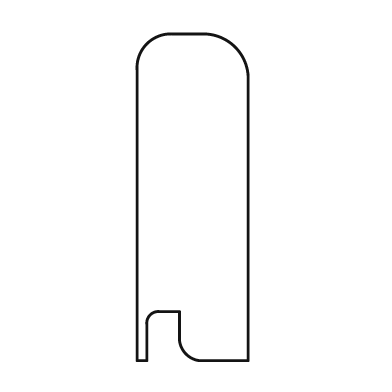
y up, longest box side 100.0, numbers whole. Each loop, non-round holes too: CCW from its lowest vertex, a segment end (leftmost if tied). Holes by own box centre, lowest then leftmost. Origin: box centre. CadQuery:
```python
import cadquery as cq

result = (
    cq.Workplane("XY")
    .moveTo(-17.0, -50.0)
    .lineTo(-14.0, -50.0)
    .lineTo(-14.0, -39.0)
    .threePointArc((-13.0, -36.0), (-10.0, -35.0))
    .lineTo(-4.0, -35.0)
    .lineTo(-4.0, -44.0)
    .threePointArc((-2.0, -48.0), (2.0, -50.0))
    .lineTo(17.0, -50.0)
    .lineTo(17.0, 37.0)
    .threePointArc((13.0, 46.0), (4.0, 50.0))
    .lineTo(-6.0, 50.0)
    .threePointArc((-14.0, 47.0), (-17.0, 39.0))
    .close()
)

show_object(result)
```